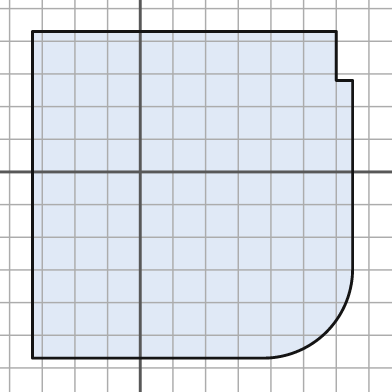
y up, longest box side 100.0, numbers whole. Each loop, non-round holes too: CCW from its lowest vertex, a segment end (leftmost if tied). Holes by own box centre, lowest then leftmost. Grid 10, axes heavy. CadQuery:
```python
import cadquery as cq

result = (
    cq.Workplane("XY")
    .moveTo(-33.0, -57.0)
    .lineTo(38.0, -57.0)
    .threePointArc((57.0, -49.0), (65.0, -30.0))
    .lineTo(65.0, 28.0)
    .lineTo(60.0, 28.0)
    .lineTo(60.0, 43.0)
    .lineTo(-33.0, 43.0)
    .close()
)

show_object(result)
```